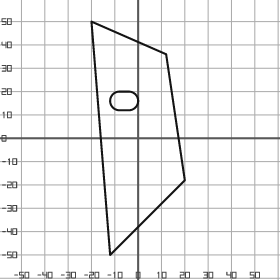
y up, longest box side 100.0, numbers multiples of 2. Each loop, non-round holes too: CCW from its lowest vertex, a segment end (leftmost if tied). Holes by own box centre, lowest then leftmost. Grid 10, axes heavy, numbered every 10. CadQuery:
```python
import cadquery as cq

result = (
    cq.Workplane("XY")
    .moveTo(-12.0, -50.0)
    .lineTo(20.0, -18.0)
    .lineTo(12.0, 36.0)
    .lineTo(-20.0, 50.0)
    .close()
    .moveTo(-8.0, 12.0)
    .lineTo(-4.0, 12.0)
    .threePointArc((0.0, 16.0), (-4.0, 20.0))
    .lineTo(-8.0, 20.0)
    .threePointArc((-12.0, 16.0), (-8.0, 12.0))
    .close()
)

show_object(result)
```